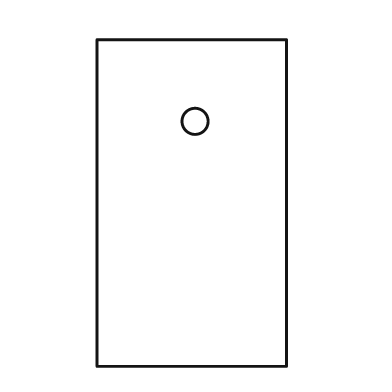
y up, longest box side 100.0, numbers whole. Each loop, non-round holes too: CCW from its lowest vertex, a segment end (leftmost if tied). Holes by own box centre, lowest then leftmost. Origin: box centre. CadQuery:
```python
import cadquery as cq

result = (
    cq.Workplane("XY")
    .moveTo(-29.0, -50.0)
    .lineTo(29.0, -50.0)
    .lineTo(29.0, 50.0)
    .lineTo(-29.0, 50.0)
    .close()
    .moveTo(1.0, 25.0)
    .circle(4.0)
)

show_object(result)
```